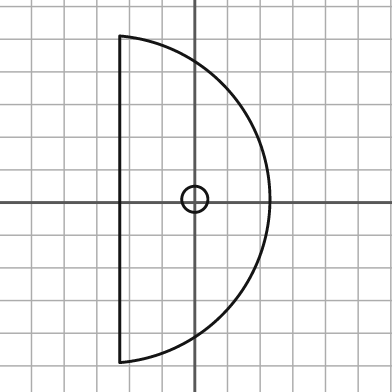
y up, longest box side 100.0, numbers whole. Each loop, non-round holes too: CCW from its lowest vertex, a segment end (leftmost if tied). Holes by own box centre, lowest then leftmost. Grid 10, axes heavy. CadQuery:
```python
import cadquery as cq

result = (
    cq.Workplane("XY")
    .moveTo(-23.0, -49.0)
    .threePointArc((23.0, 1.0), (-23.0, 51.0))
    .close()
    .moveTo(0.0, 1.0)
    .circle(4.0)
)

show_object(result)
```